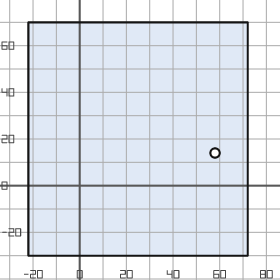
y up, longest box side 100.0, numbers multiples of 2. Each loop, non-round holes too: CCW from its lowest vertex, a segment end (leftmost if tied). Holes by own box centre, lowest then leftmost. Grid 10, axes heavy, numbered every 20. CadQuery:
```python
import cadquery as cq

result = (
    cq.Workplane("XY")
    .moveTo(-22.0, -30.0)
    .lineTo(72.0, -30.0)
    .lineTo(72.0, 70.0)
    .lineTo(-22.0, 70.0)
    .close()
    .moveTo(58.0, 14.0)
    .circle(2.0)
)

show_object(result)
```